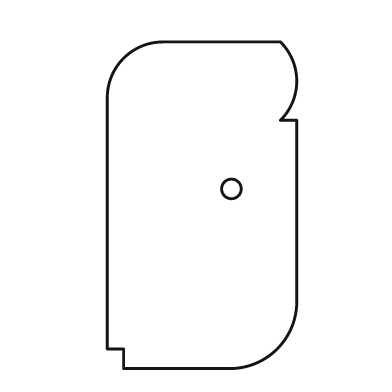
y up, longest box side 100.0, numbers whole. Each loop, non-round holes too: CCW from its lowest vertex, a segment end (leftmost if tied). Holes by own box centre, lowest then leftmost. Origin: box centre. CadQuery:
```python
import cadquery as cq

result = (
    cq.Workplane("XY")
    .moveTo(-24.0, -50.0)
    .lineTo(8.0, -50.0)
    .threePointArc((23.0, -44.0), (29.0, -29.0))
    .lineTo(29.0, 26.0)
    .lineTo(24.0, 26.0)
    .threePointArc((29.0, 38.0), (24.0, 50.0))
    .lineTo(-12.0, 50.0)
    .threePointArc((-24.0, 45.0), (-29.0, 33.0))
    .lineTo(-29.0, -44.0)
    .lineTo(-24.0, -44.0)
    .close()
    .moveTo(9.0, 5.0)
    .circle(3.0)
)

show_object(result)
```